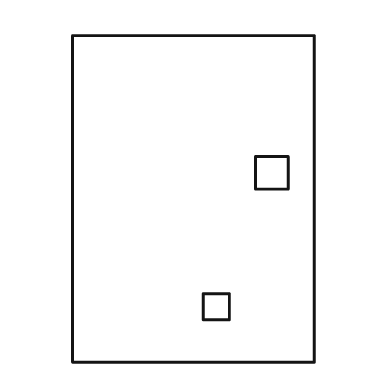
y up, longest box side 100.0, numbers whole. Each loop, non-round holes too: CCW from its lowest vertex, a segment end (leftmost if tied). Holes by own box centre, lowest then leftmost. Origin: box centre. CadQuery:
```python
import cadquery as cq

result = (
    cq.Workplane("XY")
    .moveTo(-37.0, -50.0)
    .lineTo(37.0, -50.0)
    .lineTo(37.0, 50.0)
    .lineTo(-37.0, 50.0)
    .close()
    .moveTo(3.0, -37.0)
    .lineTo(11.0, -37.0)
    .lineTo(11.0, -29.0)
    .lineTo(3.0, -29.0)
    .close()
    .moveTo(19.0, 3.0)
    .lineTo(29.0, 3.0)
    .lineTo(29.0, 13.0)
    .lineTo(19.0, 13.0)
    .close()
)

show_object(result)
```